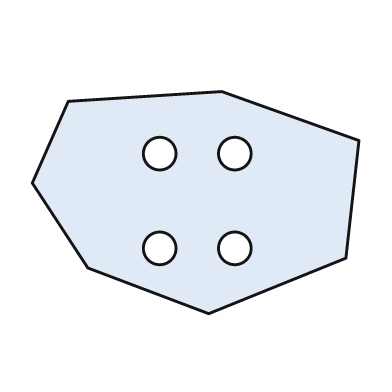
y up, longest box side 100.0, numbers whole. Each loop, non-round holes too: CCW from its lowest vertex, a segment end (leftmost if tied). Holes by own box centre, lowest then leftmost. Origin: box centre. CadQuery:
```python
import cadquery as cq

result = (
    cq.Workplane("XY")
    .moveTo(4.0, -34.0)
    .lineTo(46.0, -17.0)
    .lineTo(50.0, 19.0)
    .lineTo(8.0, 34.0)
    .lineTo(-39.0, 31.0)
    .lineTo(-50.0, 6.0)
    .lineTo(-33.0, -20.0)
    .close()
    .moveTo(-11.0, -14.0)
    .circle(5.0)
    .moveTo(12.0, -14.0)
    .circle(5.0)
    .moveTo(-11.0, 15.0)
    .circle(5.0)
    .moveTo(12.0, 15.0)
    .circle(5.0)
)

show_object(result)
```